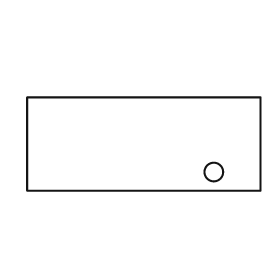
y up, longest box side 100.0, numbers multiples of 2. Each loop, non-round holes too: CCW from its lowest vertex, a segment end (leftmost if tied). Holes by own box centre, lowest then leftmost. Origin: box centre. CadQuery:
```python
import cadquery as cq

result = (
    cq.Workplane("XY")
    .moveTo(-50.0, -20.0)
    .lineTo(50.0, -20.0)
    .lineTo(50.0, 20.0)
    .lineTo(-50.0, 20.0)
    .close()
    .moveTo(30.0, -12.0)
    .circle(4.0)
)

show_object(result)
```